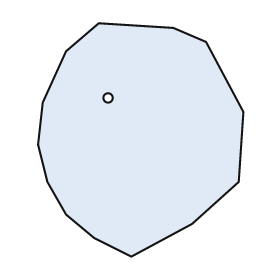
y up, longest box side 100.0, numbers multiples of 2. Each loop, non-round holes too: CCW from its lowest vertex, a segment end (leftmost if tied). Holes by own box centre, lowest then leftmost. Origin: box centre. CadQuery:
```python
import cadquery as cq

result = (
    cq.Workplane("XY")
    .moveTo(-4.0, -50.0)
    .lineTo(22.0, -36.0)
    .lineTo(42.0, -18.0)
    .lineTo(44.0, 12.0)
    .lineTo(28.0, 42.0)
    .lineTo(14.0, 48.0)
    .lineTo(-18.0, 50.0)
    .lineTo(-32.0, 38.0)
    .lineTo(-42.0, 16.0)
    .lineTo(-44.0, -2.0)
    .lineTo(-40.0, -18.0)
    .lineTo(-32.0, -32.0)
    .lineTo(-20.0, -42.0)
    .close()
    .moveTo(-14.0, 18.0)
    .circle(2.0)
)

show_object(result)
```